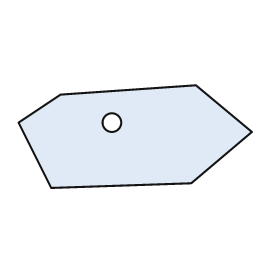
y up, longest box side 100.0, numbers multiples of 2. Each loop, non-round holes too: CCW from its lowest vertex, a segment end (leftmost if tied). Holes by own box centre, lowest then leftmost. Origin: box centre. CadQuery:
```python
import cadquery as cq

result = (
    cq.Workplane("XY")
    .moveTo(-36.0, -22.0)
    .lineTo(24.0, -20.0)
    .lineTo(50.0, 2.0)
    .lineTo(26.0, 22.0)
    .lineTo(-32.0, 18.0)
    .lineTo(-50.0, 6.0)
    .close()
    .moveTo(-10.0, 6.0)
    .circle(4.0)
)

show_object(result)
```